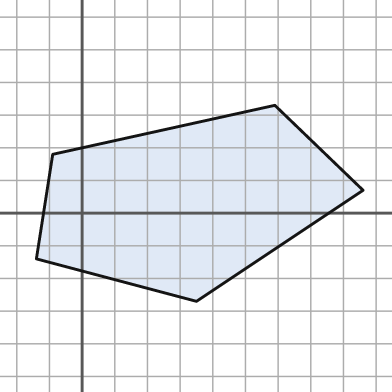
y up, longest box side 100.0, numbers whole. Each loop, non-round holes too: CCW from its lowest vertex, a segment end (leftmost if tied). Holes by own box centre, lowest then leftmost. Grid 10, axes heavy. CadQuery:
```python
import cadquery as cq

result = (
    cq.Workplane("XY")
    .moveTo(35.0, -27.0)
    .lineTo(86.0, 7.0)
    .lineTo(59.0, 33.0)
    .lineTo(-9.0, 18.0)
    .lineTo(-14.0, -14.0)
    .close()
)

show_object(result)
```